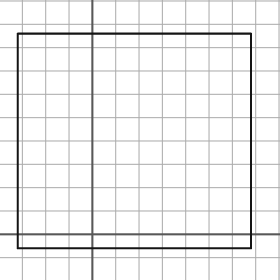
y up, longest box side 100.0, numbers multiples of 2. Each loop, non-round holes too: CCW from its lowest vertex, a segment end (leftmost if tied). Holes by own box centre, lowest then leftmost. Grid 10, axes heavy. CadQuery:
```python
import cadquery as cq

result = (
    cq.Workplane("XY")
    .moveTo(-32.0, -6.0)
    .lineTo(68.0, -6.0)
    .lineTo(68.0, 86.0)
    .lineTo(-32.0, 86.0)
    .close()
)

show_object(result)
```